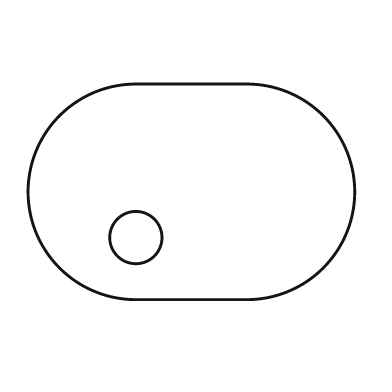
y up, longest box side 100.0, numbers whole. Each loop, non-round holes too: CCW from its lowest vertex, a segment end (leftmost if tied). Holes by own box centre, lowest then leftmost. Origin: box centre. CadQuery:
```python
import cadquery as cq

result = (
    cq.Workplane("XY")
    .moveTo(-17.0, -33.0)
    .lineTo(17.0, -33.0)
    .threePointArc((50.0, 0.0), (17.0, 33.0))
    .lineTo(-17.0, 33.0)
    .threePointArc((-50.0, 0.0), (-17.0, -33.0))
    .close()
    .moveTo(-17.0, -14.0)
    .circle(8.0)
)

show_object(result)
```